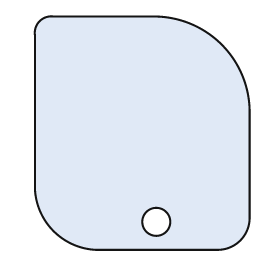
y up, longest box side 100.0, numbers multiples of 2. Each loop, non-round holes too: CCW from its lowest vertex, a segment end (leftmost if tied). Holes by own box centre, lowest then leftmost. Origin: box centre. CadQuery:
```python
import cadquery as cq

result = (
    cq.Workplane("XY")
    .moveTo(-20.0, -50.0)
    .lineTo(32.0, -50.0)
    .threePointArc((42.0, -46.0), (46.0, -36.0))
    .lineTo(46.0, 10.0)
    .threePointArc((34.0, 38.0), (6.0, 50.0))
    .lineTo(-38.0, 50.0)
    .threePointArc((-44.0, 48.0), (-46.0, 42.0))
    .lineTo(-46.0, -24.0)
    .threePointArc((-38.0, -42.0), (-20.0, -50.0))
    .close()
    .moveTo(6.0, -38.0)
    .circle(6.0)
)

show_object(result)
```